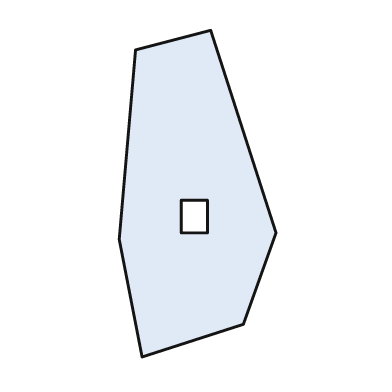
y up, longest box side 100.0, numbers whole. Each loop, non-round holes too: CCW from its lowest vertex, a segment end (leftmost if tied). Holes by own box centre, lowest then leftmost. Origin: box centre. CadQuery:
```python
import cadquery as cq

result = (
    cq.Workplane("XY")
    .moveTo(-17.0, -50.0)
    .lineTo(14.0, -40.0)
    .lineTo(24.0, -12.0)
    .lineTo(4.0, 50.0)
    .lineTo(-19.0, 44.0)
    .lineTo(-24.0, -14.0)
    .close()
    .moveTo(-5.0, -12.0)
    .lineTo(3.0, -12.0)
    .lineTo(3.0, -2.0)
    .lineTo(-5.0, -2.0)
    .close()
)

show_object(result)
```